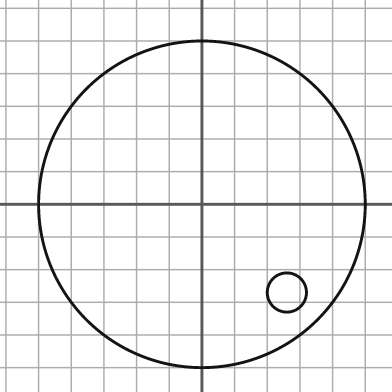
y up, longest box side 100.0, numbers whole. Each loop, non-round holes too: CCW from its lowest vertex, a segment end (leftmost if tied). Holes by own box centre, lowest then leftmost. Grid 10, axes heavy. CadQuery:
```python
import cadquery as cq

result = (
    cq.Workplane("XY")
    .moveTo(0.0, 0.0)
    .circle(50.0)
    .moveTo(26.0, -27.0)
    .circle(6.0)
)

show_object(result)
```